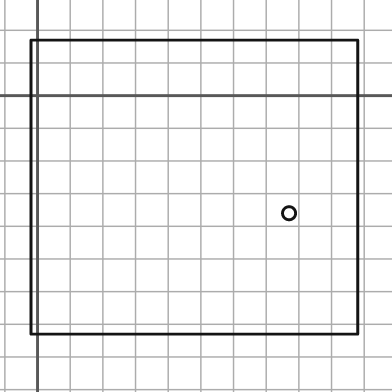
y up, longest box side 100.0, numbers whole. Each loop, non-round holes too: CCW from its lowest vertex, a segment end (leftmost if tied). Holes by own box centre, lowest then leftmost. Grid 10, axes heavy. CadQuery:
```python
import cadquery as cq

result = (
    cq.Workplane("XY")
    .moveTo(-2.0, -73.0)
    .lineTo(98.0, -73.0)
    .lineTo(98.0, 17.0)
    .lineTo(-2.0, 17.0)
    .close()
    .moveTo(77.0, -36.0)
    .circle(2.0)
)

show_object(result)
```